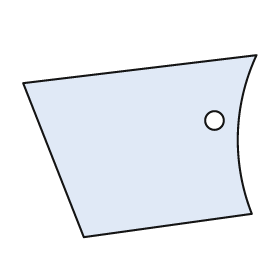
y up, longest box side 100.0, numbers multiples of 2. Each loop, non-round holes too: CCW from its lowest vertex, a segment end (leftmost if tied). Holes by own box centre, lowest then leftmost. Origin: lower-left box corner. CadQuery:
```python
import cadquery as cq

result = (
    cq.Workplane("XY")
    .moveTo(26.0, 0.0)
    .lineTo(98.0, 10.0)
    .threePointArc((92.0, 44.0), (100.0, 78.0))
    .lineTo(0.0, 66.0)
    .close()
    .moveTo(82.0, 50.0)
    .circle(4.0)
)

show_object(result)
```